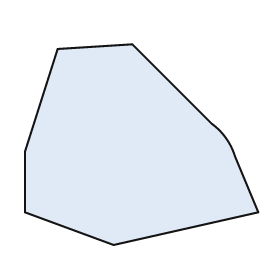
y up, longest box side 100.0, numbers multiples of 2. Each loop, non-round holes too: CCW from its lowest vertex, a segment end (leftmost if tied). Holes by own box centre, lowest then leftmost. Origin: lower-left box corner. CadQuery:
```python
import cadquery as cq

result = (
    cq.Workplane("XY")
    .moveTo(38.0, 0.0)
    .lineTo(100.0, 14.0)
    .lineTo(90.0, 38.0)
    .threePointArc((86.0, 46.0), (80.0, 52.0))
    .lineTo(46.0, 86.0)
    .lineTo(14.0, 84.0)
    .lineTo(0.0, 40.0)
    .lineTo(0.0, 14.0)
    .close()
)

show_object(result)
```